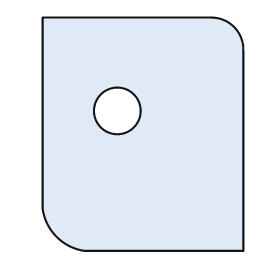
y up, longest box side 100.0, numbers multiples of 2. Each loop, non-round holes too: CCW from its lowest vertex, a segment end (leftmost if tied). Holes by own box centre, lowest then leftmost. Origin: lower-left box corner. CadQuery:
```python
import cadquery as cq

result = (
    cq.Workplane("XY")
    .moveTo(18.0, 0.0)
    .lineTo(86.0, 0.0)
    .lineTo(86.0, 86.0)
    .threePointArc((82.0, 96.0), (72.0, 100.0))
    .lineTo(0.0, 100.0)
    .lineTo(0.0, 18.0)
    .threePointArc((6.0, 6.0), (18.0, 0.0))
    .close()
    .moveTo(32.0, 60.0)
    .circle(10.0)
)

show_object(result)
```